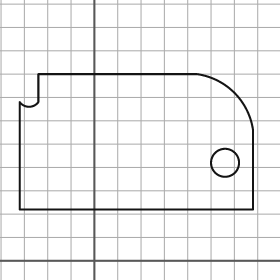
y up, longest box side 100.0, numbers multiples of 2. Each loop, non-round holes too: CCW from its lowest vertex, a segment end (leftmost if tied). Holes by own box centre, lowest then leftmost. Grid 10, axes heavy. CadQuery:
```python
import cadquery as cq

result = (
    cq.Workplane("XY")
    .moveTo(-32.0, 22.0)
    .lineTo(68.0, 22.0)
    .lineTo(68.0, 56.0)
    .threePointArc((60.0, 72.0), (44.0, 80.0))
    .lineTo(-24.0, 80.0)
    .lineTo(-24.0, 68.0)
    .threePointArc((-28.0, 66.0), (-32.0, 68.0))
    .close()
    .moveTo(56.0, 42.0)
    .circle(6.0)
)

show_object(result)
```